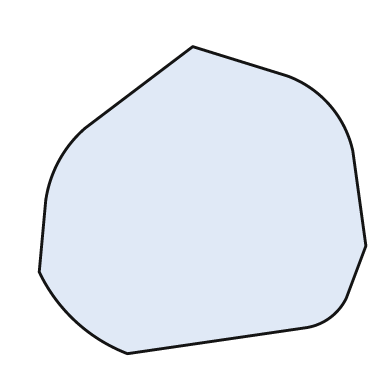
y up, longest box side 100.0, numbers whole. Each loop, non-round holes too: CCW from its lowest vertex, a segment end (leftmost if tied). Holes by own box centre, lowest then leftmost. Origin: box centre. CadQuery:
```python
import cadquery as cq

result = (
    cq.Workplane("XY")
    .moveTo(-23.0, -47.0)
    .lineTo(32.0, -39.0)
    .threePointArc((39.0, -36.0), (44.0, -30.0))
    .lineTo(50.0, -14.0)
    .lineTo(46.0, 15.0)
    .threePointArc((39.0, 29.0), (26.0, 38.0))
    .lineTo(-3.0, 47.0)
    .lineTo(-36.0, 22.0)
    .threePointArc((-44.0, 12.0), (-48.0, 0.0))
    .lineTo(-50.0, -22.0)
    .threePointArc((-39.0, -37.0), (-23.0, -47.0))
    .close()
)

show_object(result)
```